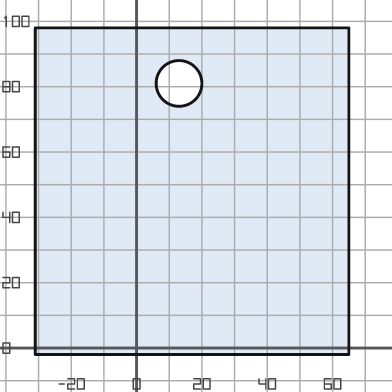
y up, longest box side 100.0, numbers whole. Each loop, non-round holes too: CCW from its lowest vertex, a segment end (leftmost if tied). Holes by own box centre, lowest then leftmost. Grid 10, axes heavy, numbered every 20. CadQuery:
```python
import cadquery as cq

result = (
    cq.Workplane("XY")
    .moveTo(-31.0, -2.0)
    .lineTo(65.0, -2.0)
    .lineTo(65.0, 98.0)
    .lineTo(-31.0, 98.0)
    .close()
    .moveTo(13.0, 81.0)
    .circle(7.0)
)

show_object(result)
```